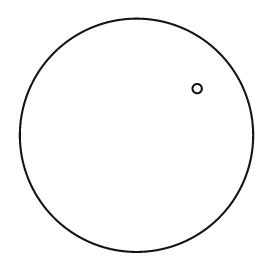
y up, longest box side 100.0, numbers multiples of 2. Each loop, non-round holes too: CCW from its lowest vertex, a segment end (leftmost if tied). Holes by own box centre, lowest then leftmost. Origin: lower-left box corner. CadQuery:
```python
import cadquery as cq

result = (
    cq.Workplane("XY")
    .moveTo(50.0, 50.0)
    .circle(50.0)
    .moveTo(76.0, 70.0)
    .circle(2.0)
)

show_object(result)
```